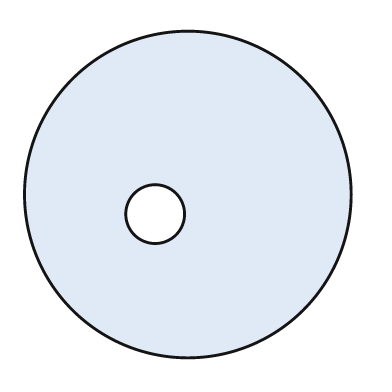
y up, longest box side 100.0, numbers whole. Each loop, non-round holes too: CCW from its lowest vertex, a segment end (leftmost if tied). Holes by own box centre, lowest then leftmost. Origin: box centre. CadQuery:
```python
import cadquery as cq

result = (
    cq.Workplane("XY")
    .moveTo(0.0, 0.0)
    .circle(50.0)
    .moveTo(-10.0, -6.0)
    .circle(9.0)
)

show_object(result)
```